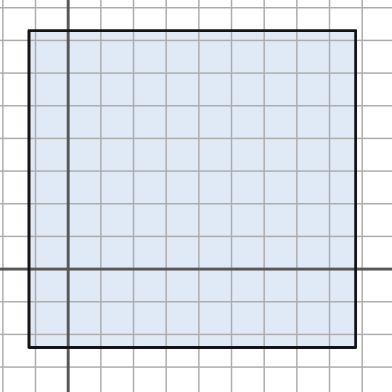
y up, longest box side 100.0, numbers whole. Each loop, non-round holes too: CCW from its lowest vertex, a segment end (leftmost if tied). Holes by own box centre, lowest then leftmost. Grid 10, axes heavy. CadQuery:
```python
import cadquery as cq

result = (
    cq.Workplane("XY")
    .moveTo(-12.0, -24.0)
    .lineTo(88.0, -24.0)
    .lineTo(88.0, 73.0)
    .lineTo(-12.0, 73.0)
    .close()
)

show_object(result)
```